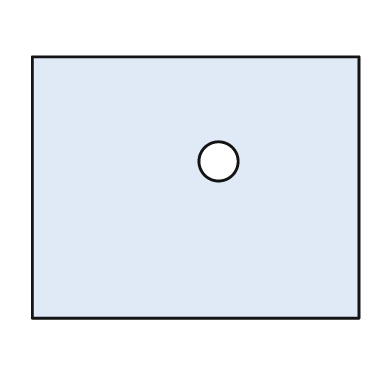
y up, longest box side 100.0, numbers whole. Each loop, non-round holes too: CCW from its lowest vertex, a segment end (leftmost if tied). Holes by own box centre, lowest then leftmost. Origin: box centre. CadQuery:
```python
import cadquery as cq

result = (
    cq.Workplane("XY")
    .moveTo(-50.0, -40.0)
    .lineTo(50.0, -40.0)
    .lineTo(50.0, 40.0)
    .lineTo(-50.0, 40.0)
    .close()
    .moveTo(7.0, 8.0)
    .circle(6.0)
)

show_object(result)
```